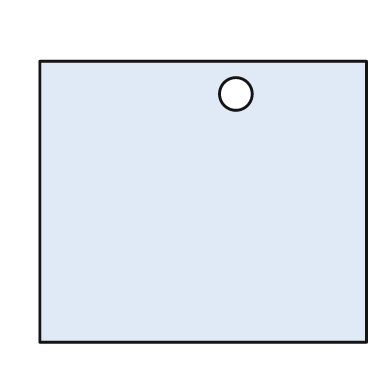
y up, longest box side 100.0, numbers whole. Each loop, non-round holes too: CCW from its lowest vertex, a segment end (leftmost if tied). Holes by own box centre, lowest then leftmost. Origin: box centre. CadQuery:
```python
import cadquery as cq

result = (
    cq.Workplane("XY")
    .moveTo(-50.0, -43.0)
    .lineTo(50.0, -43.0)
    .lineTo(50.0, 43.0)
    .lineTo(-50.0, 43.0)
    .close()
    .moveTo(10.0, 33.0)
    .circle(5.0)
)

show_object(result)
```